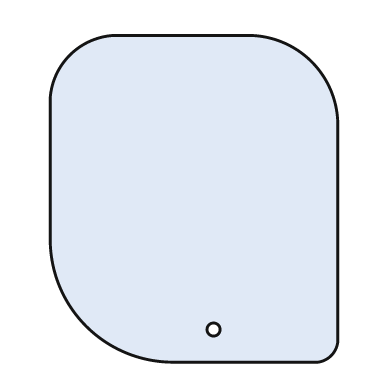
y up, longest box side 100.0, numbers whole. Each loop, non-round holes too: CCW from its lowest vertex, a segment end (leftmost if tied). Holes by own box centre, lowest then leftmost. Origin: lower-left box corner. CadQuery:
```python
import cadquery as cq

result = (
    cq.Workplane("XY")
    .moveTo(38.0, 0.0)
    .lineTo(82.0, 0.0)
    .threePointArc((86.0, 2.0), (88.0, 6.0))
    .lineTo(88.0, 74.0)
    .threePointArc((80.0, 92.0), (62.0, 100.0))
    .lineTo(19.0, 100.0)
    .threePointArc((6.0, 94.0), (0.0, 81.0))
    .lineTo(0.0, 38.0)
    .threePointArc((11.0, 11.0), (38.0, 0.0))
    .close()
    .moveTo(50.0, 10.0)
    .circle(2.0)
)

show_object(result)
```